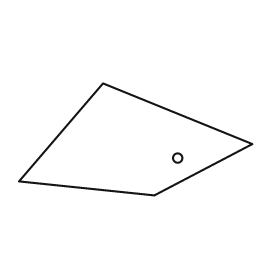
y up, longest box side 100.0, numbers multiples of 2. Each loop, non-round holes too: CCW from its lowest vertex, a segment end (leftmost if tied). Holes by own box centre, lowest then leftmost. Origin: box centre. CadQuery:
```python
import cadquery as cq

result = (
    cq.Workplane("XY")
    .moveTo(8.0, -24.0)
    .lineTo(50.0, -2.0)
    .lineTo(-14.0, 24.0)
    .lineTo(-50.0, -18.0)
    .close()
    .moveTo(18.0, -8.0)
    .circle(2.0)
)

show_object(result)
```